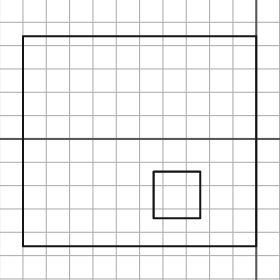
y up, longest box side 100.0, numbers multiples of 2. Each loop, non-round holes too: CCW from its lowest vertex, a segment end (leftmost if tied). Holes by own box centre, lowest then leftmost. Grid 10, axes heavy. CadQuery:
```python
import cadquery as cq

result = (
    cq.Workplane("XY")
    .moveTo(-100.0, -46.0)
    .lineTo(0.0, -46.0)
    .lineTo(0.0, 44.0)
    .lineTo(-100.0, 44.0)
    .close()
    .moveTo(-44.0, -34.0)
    .lineTo(-24.0, -34.0)
    .lineTo(-24.0, -14.0)
    .lineTo(-44.0, -14.0)
    .close()
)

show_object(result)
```